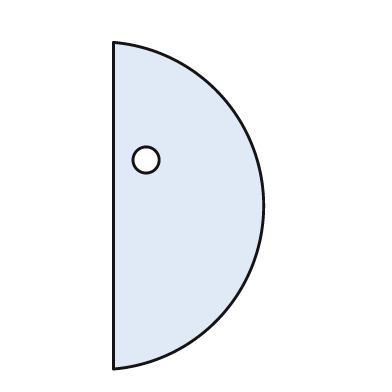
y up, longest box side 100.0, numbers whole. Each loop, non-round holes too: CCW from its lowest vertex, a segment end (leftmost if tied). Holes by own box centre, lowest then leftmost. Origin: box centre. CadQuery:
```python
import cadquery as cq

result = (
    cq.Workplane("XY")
    .moveTo(-23.0, -50.0)
    .threePointArc((23.0, 0.0), (-23.0, 50.0))
    .close()
    .moveTo(-13.0, 14.0)
    .circle(4.0)
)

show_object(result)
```